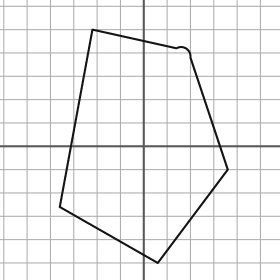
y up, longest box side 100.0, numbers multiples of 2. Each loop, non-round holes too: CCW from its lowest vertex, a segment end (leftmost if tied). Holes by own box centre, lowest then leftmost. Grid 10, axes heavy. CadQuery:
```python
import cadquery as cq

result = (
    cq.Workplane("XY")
    .moveTo(6.0, -50.0)
    .lineTo(36.0, -10.0)
    .lineTo(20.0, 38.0)
    .threePointArc((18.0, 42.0), (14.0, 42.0))
    .lineTo(-22.0, 50.0)
    .lineTo(-36.0, -26.0)
    .close()
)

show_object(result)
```